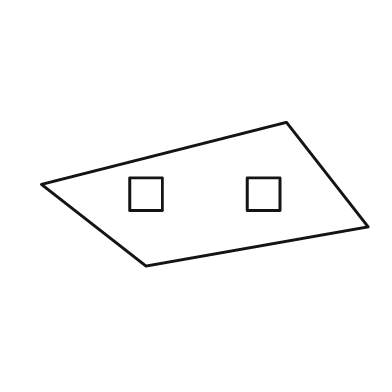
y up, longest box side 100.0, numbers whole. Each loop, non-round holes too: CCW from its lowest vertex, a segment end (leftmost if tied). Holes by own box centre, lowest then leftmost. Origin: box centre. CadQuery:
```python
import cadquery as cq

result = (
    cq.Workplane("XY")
    .moveTo(-18.0, -22.0)
    .lineTo(50.0, -10.0)
    .lineTo(25.0, 22.0)
    .lineTo(-50.0, 3.0)
    .close()
    .moveTo(-23.0, -5.0)
    .lineTo(-13.0, -5.0)
    .lineTo(-13.0, 5.0)
    .lineTo(-23.0, 5.0)
    .close()
    .moveTo(13.0, -5.0)
    .lineTo(23.0, -5.0)
    .lineTo(23.0, 5.0)
    .lineTo(13.0, 5.0)
    .close()
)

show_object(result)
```